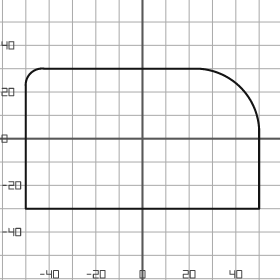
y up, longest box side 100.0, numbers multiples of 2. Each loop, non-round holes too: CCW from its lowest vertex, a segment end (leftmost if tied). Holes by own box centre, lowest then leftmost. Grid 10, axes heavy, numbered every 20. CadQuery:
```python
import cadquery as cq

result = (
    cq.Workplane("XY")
    .moveTo(-50.0, -30.0)
    .lineTo(50.0, -30.0)
    .lineTo(50.0, 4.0)
    .threePointArc((42.0, 22.0), (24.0, 30.0))
    .lineTo(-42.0, 30.0)
    .threePointArc((-48.0, 28.0), (-50.0, 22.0))
    .close()
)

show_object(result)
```